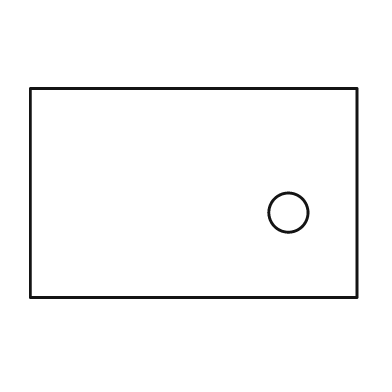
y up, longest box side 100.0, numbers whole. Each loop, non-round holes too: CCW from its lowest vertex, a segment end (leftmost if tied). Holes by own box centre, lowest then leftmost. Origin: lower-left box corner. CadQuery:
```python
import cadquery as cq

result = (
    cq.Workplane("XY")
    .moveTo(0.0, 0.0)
    .lineTo(100.0, 0.0)
    .lineTo(100.0, 64.0)
    .lineTo(0.0, 64.0)
    .close()
    .moveTo(79.0, 26.0)
    .circle(6.0)
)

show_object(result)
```